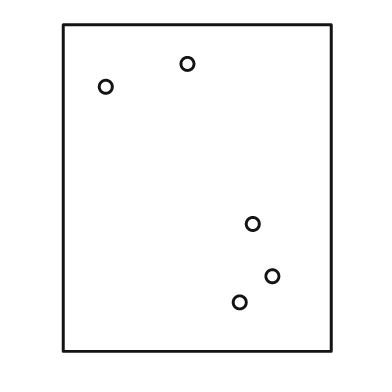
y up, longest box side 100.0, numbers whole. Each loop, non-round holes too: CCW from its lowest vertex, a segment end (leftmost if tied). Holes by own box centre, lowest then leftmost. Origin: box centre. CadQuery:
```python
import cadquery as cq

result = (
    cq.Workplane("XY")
    .moveTo(-41.0, -50.0)
    .lineTo(41.0, -50.0)
    .lineTo(41.0, 50.0)
    .lineTo(-41.0, 50.0)
    .close()
    .moveTo(13.0, -35.0)
    .circle(2.0)
    .moveTo(23.0, -27.0)
    .circle(2.0)
    .moveTo(17.0, -11.0)
    .circle(2.0)
    .moveTo(-28.0, 31.0)
    .circle(2.0)
    .moveTo(-3.0, 38.0)
    .circle(2.0)
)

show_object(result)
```